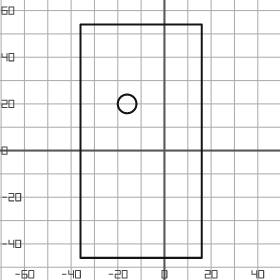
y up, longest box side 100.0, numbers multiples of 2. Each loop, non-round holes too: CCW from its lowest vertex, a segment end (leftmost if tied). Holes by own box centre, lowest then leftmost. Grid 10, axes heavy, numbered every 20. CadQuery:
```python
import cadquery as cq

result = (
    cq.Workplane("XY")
    .moveTo(-36.0, -46.0)
    .lineTo(16.0, -46.0)
    .lineTo(16.0, 54.0)
    .lineTo(-36.0, 54.0)
    .close()
    .moveTo(-16.0, 20.0)
    .circle(4.0)
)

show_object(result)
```